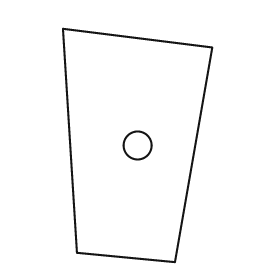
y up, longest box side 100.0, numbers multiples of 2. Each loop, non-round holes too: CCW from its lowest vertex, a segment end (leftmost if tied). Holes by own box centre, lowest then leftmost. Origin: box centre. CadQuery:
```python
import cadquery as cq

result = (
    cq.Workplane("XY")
    .moveTo(16.0, -50.0)
    .lineTo(32.0, 42.0)
    .lineTo(-32.0, 50.0)
    .lineTo(-26.0, -46.0)
    .close()
    .moveTo(0.0, 0.0)
    .circle(6.0)
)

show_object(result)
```